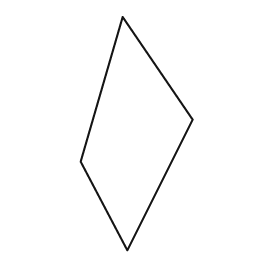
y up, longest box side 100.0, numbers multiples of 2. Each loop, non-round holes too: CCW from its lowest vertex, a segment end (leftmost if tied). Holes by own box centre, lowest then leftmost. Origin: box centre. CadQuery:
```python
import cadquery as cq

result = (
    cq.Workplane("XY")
    .moveTo(-4.0, -50.0)
    .lineTo(24.0, 6.0)
    .lineTo(-6.0, 50.0)
    .lineTo(-24.0, -12.0)
    .close()
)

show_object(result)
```